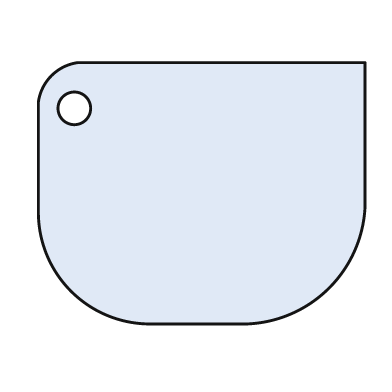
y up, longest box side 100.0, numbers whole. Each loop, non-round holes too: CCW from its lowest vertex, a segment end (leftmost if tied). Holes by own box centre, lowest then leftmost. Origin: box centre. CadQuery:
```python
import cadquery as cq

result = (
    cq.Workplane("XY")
    .moveTo(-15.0, -40.0)
    .lineTo(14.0, -40.0)
    .threePointArc((39.0, -29.0), (50.0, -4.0))
    .lineTo(50.0, 40.0)
    .lineTo(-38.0, 40.0)
    .threePointArc((-46.0, 36.0), (-50.0, 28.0))
    .lineTo(-50.0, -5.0)
    .threePointArc((-40.0, -30.0), (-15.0, -40.0))
    .close()
    .moveTo(-39.0, 26.0)
    .circle(5.0)
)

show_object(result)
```